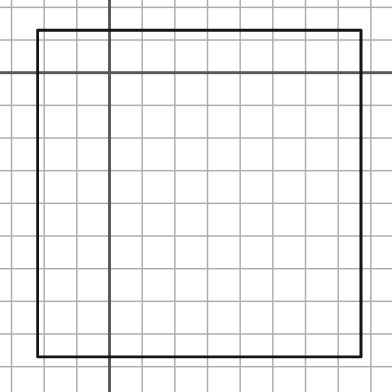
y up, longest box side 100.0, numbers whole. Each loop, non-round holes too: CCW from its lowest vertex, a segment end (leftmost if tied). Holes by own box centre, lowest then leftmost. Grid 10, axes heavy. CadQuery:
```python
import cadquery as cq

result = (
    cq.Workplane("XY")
    .moveTo(-22.0, -87.0)
    .lineTo(77.0, -87.0)
    .lineTo(77.0, 13.0)
    .lineTo(-22.0, 13.0)
    .close()
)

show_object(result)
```